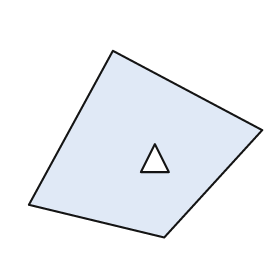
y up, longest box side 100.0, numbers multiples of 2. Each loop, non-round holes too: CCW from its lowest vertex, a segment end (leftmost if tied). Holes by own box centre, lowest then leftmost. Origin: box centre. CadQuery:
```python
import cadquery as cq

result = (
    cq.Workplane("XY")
    .moveTo(8.0, -40.0)
    .lineTo(50.0, 6.0)
    .lineTo(-14.0, 40.0)
    .lineTo(-50.0, -26.0)
    .close()
    .moveTo(-2.0, -12.0)
    .lineTo(10.0, -12.0)
    .lineTo(4.0, 0.0)
    .close()
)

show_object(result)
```